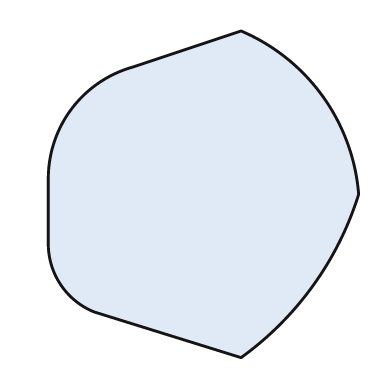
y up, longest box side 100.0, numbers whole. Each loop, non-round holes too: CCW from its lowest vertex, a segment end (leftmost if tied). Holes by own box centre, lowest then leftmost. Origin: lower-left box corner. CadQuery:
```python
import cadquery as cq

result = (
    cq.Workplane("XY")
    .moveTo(59.0, 0.0)
    .threePointArc((81.0, 22.0), (95.0, 50.0))
    .threePointArc((84.0, 80.0), (59.0, 100.0))
    .lineTo(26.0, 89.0)
    .threePointArc((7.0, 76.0), (0.0, 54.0))
    .lineTo(0.0, 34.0)
    .threePointArc((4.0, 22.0), (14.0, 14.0))
    .close()
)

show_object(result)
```